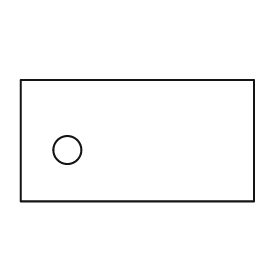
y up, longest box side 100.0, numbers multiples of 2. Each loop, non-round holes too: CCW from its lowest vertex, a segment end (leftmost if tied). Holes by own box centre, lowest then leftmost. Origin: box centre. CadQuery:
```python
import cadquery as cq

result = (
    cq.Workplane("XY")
    .moveTo(-50.0, -26.0)
    .lineTo(50.0, -26.0)
    .lineTo(50.0, 26.0)
    .lineTo(-50.0, 26.0)
    .close()
    .moveTo(-30.0, -4.0)
    .circle(6.0)
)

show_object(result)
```